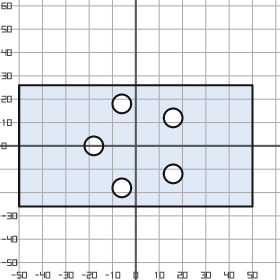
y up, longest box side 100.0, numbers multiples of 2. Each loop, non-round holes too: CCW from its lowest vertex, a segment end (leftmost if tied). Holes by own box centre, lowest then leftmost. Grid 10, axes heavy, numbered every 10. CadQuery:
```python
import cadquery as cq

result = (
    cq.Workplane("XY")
    .moveTo(-50.0, -26.0)
    .lineTo(50.0, -26.0)
    .lineTo(50.0, 26.0)
    .lineTo(-50.0, 26.0)
    .close()
    .moveTo(-6.0, -18.0)
    .circle(4.0)
    .moveTo(16.0, -12.0)
    .circle(4.0)
    .moveTo(-18.0, 0.0)
    .circle(4.0)
    .moveTo(16.0, 12.0)
    .circle(4.0)
    .moveTo(-6.0, 18.0)
    .circle(4.0)
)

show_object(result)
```